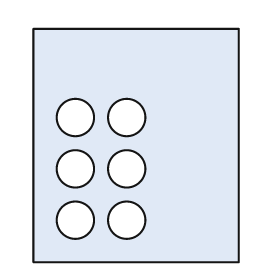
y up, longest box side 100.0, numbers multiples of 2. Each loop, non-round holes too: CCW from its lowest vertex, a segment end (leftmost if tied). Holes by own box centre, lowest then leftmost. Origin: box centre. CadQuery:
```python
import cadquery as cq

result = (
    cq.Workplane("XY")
    .moveTo(-44.0, -50.0)
    .lineTo(44.0, -50.0)
    .lineTo(44.0, 50.0)
    .lineTo(-44.0, 50.0)
    .close()
    .moveTo(-26.0, -32.0)
    .circle(8.0)
    .moveTo(-4.0, -32.0)
    .circle(8.0)
    .moveTo(-26.0, -10.0)
    .circle(8.0)
    .moveTo(-4.0, -10.0)
    .circle(8.0)
    .moveTo(-26.0, 12.0)
    .circle(8.0)
    .moveTo(-4.0, 12.0)
    .circle(8.0)
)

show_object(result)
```